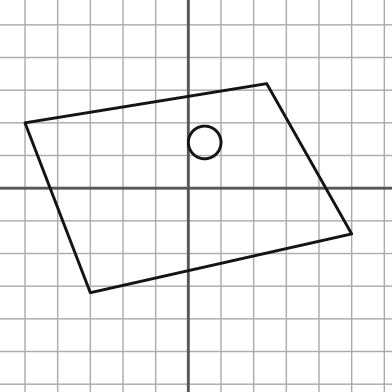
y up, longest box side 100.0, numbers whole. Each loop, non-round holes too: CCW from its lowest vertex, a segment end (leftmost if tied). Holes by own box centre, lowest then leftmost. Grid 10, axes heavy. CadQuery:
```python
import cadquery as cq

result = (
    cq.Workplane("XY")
    .moveTo(-30.0, -32.0)
    .lineTo(50.0, -14.0)
    .lineTo(24.0, 32.0)
    .lineTo(-50.0, 20.0)
    .close()
    .moveTo(5.0, 14.0)
    .circle(5.0)
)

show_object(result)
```